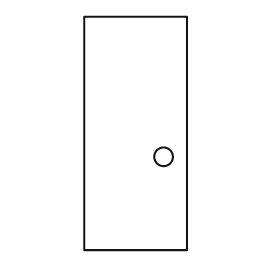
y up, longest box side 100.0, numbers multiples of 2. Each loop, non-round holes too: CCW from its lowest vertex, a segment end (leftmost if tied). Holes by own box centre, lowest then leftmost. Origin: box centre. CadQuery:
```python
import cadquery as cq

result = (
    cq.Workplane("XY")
    .moveTo(-22.0, -50.0)
    .lineTo(22.0, -50.0)
    .lineTo(22.0, 50.0)
    .lineTo(-22.0, 50.0)
    .close()
    .moveTo(12.0, -10.0)
    .circle(4.0)
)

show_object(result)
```